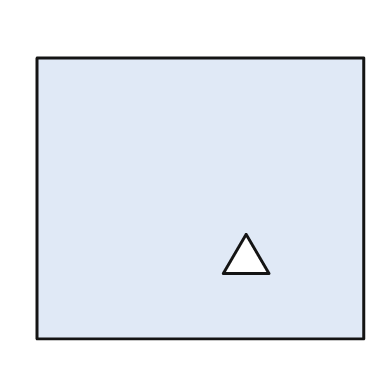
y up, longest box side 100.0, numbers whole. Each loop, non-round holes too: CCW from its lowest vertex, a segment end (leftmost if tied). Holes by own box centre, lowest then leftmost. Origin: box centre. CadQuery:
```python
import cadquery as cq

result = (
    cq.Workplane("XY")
    .moveTo(-50.0, -43.0)
    .lineTo(50.0, -43.0)
    .lineTo(50.0, 43.0)
    .lineTo(-50.0, 43.0)
    .close()
    .moveTo(7.0, -23.0)
    .lineTo(21.0, -23.0)
    .lineTo(14.0, -11.0)
    .close()
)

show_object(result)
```